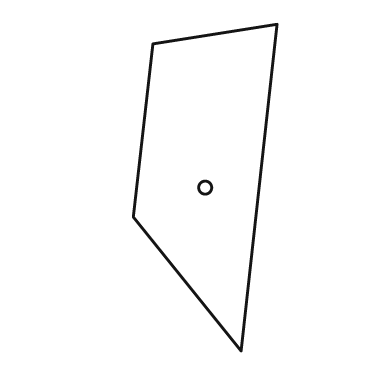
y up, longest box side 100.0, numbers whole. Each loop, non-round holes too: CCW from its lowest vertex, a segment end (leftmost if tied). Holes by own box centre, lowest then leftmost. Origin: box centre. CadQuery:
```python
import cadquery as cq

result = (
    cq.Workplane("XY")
    .moveTo(11.0, -50.0)
    .lineTo(22.0, 50.0)
    .lineTo(-16.0, 44.0)
    .lineTo(-22.0, -9.0)
    .close()
    .moveTo(0.0, 0.0)
    .circle(2.0)
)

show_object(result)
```